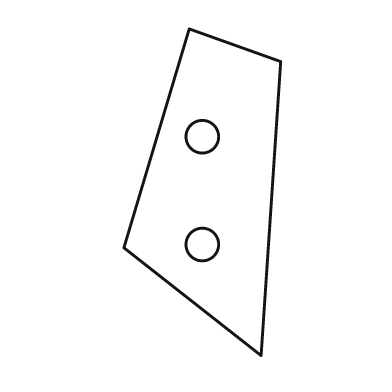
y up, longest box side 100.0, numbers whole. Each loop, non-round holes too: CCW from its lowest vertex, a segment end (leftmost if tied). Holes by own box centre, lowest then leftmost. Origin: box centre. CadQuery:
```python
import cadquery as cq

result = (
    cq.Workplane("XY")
    .moveTo(18.0, -50.0)
    .lineTo(24.0, 40.0)
    .lineTo(-4.0, 50.0)
    .lineTo(-24.0, -17.0)
    .close()
    .moveTo(0.0, -16.0)
    .circle(5.0)
    .moveTo(0.0, 17.0)
    .circle(5.0)
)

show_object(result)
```